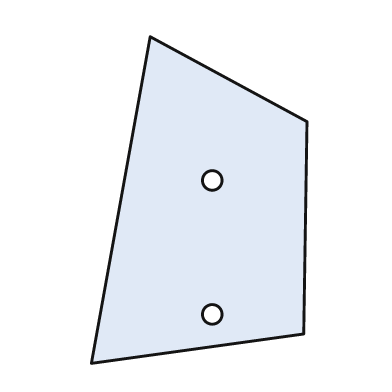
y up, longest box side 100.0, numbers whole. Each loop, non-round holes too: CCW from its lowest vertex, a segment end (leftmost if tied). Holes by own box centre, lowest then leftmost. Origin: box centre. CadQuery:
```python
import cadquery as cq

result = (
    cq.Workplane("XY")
    .moveTo(-33.0, -50.0)
    .lineTo(32.0, -41.0)
    .lineTo(33.0, 24.0)
    .lineTo(-15.0, 50.0)
    .close()
    .moveTo(4.0, -35.0)
    .circle(3.0)
    .moveTo(4.0, 6.0)
    .circle(3.0)
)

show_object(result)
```